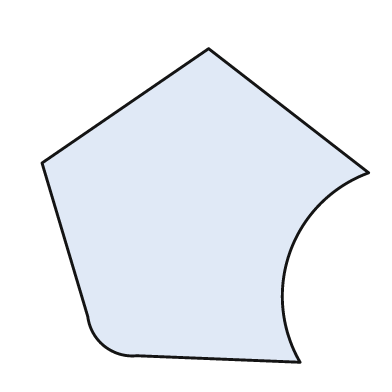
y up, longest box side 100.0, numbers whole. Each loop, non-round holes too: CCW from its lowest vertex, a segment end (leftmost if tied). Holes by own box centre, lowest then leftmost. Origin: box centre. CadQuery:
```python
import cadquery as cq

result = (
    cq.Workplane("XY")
    .moveTo(29.0, -48.0)
    .threePointArc((26.0, -14.0), (50.0, 10.0))
    .lineTo(1.0, 48.0)
    .lineTo(-50.0, 13.0)
    .lineTo(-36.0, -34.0)
    .threePointArc((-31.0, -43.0), (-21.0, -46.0))
    .close()
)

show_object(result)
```